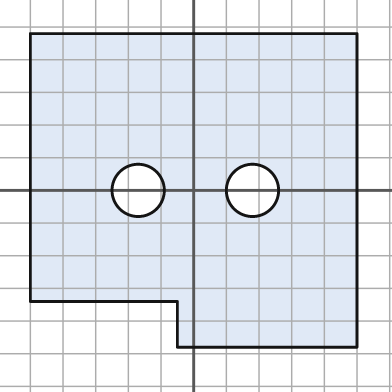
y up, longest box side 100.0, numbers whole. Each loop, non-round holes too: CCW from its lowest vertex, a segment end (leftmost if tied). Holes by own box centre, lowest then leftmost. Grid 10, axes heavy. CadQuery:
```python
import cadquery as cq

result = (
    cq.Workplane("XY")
    .moveTo(-5.0, -48.0)
    .lineTo(50.0, -48.0)
    .lineTo(50.0, 48.0)
    .lineTo(-50.0, 48.0)
    .lineTo(-50.0, -34.0)
    .lineTo(-5.0, -34.0)
    .close()
    .moveTo(-17.0, 0.0)
    .circle(8.0)
    .moveTo(18.0, 0.0)
    .circle(8.0)
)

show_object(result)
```